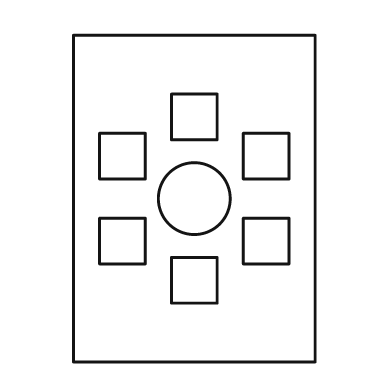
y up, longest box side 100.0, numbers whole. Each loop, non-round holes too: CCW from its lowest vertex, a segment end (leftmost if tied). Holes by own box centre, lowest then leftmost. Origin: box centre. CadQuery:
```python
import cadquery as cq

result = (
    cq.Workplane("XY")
    .moveTo(-37.0, -50.0)
    .lineTo(37.0, -50.0)
    .lineTo(37.0, 50.0)
    .lineTo(-37.0, 50.0)
    .close()
    .moveTo(-7.0, -32.0)
    .lineTo(7.0, -32.0)
    .lineTo(7.0, -18.0)
    .lineTo(-7.0, -18.0)
    .close()
    .moveTo(-29.0, -20.0)
    .lineTo(-15.0, -20.0)
    .lineTo(-15.0, -6.0)
    .lineTo(-29.0, -6.0)
    .close()
    .moveTo(15.0, -20.0)
    .lineTo(29.0, -20.0)
    .lineTo(29.0, -6.0)
    .lineTo(15.0, -6.0)
    .close()
    .moveTo(0.0, 0.0)
    .circle(11.0)
    .moveTo(-29.0, 6.0)
    .lineTo(-15.0, 6.0)
    .lineTo(-15.0, 20.0)
    .lineTo(-29.0, 20.0)
    .close()
    .moveTo(15.0, 6.0)
    .lineTo(29.0, 6.0)
    .lineTo(29.0, 20.0)
    .lineTo(15.0, 20.0)
    .close()
    .moveTo(-7.0, 18.0)
    .lineTo(7.0, 18.0)
    .lineTo(7.0, 32.0)
    .lineTo(-7.0, 32.0)
    .close()
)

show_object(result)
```